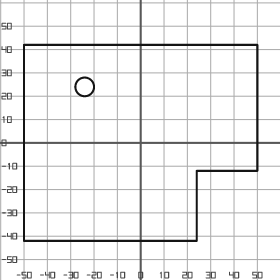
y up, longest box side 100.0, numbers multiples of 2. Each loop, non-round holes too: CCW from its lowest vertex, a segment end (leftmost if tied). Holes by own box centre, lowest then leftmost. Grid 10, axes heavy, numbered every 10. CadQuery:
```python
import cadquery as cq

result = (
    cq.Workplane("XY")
    .moveTo(-50.0, -42.0)
    .lineTo(24.0, -42.0)
    .lineTo(24.0, -12.0)
    .lineTo(50.0, -12.0)
    .lineTo(50.0, 42.0)
    .lineTo(-50.0, 42.0)
    .close()
    .moveTo(-24.0, 24.0)
    .circle(4.0)
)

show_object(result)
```